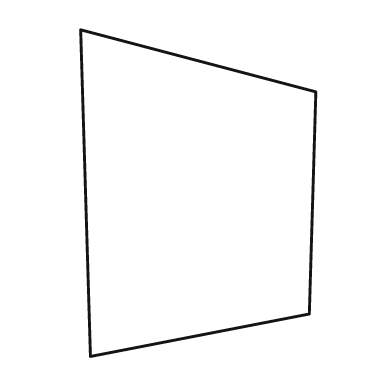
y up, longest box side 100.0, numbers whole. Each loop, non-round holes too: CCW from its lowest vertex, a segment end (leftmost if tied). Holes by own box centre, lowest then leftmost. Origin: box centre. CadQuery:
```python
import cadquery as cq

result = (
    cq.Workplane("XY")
    .moveTo(-33.0, -50.0)
    .lineTo(34.0, -37.0)
    .lineTo(36.0, 31.0)
    .lineTo(-36.0, 50.0)
    .close()
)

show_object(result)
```